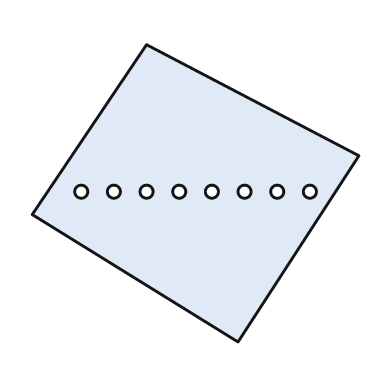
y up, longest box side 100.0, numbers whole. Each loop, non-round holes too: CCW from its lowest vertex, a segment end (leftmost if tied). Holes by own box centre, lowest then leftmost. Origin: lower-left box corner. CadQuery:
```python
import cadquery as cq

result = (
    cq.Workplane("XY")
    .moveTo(63.0, 0.0)
    .lineTo(100.0, 57.0)
    .lineTo(35.0, 91.0)
    .lineTo(0.0, 39.0)
    .close()
    .moveTo(15.0, 46.0)
    .circle(2.0)
    .moveTo(25.0, 46.0)
    .circle(2.0)
    .moveTo(35.0, 46.0)
    .circle(2.0)
    .moveTo(45.0, 46.0)
    .circle(2.0)
    .moveTo(55.0, 46.0)
    .circle(2.0)
    .moveTo(65.0, 46.0)
    .circle(2.0)
    .moveTo(75.0, 46.0)
    .circle(2.0)
    .moveTo(85.0, 46.0)
    .circle(2.0)
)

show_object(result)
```